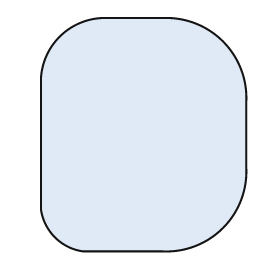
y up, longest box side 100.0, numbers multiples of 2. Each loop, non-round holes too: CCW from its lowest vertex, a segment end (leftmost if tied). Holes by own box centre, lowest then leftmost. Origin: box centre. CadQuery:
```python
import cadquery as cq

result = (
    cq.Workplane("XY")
    .moveTo(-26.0, -50.0)
    .lineTo(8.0, -50.0)
    .threePointArc((34.0, -40.0), (44.0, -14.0))
    .lineTo(44.0, 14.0)
    .threePointArc((34.0, 40.0), (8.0, 50.0))
    .lineTo(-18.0, 50.0)
    .threePointArc((-36.0, 42.0), (-44.0, 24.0))
    .lineTo(-44.0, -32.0)
    .threePointArc((-38.0, -44.0), (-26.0, -50.0))
    .close()
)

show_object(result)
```